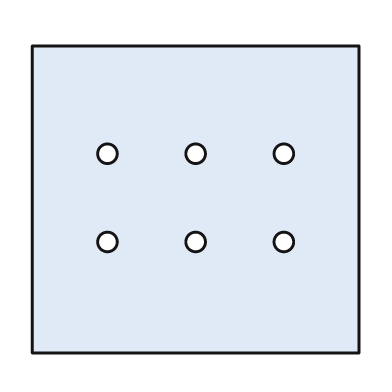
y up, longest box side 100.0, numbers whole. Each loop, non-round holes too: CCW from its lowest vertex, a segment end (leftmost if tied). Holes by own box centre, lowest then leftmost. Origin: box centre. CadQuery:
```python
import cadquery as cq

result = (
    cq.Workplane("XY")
    .moveTo(-50.0, -47.0)
    .lineTo(50.0, -47.0)
    .lineTo(50.0, 47.0)
    .lineTo(-50.0, 47.0)
    .close()
    .moveTo(-27.0, -13.0)
    .circle(3.0)
    .moveTo(0.0, -13.0)
    .circle(3.0)
    .moveTo(27.0, -13.0)
    .circle(3.0)
    .moveTo(-27.0, 14.0)
    .circle(3.0)
    .moveTo(0.0, 14.0)
    .circle(3.0)
    .moveTo(27.0, 14.0)
    .circle(3.0)
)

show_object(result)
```